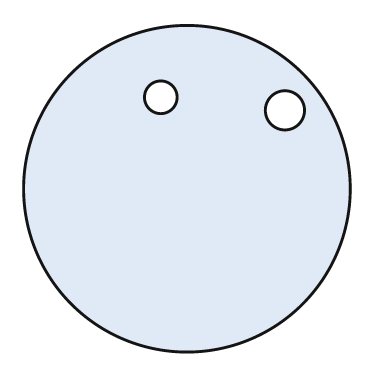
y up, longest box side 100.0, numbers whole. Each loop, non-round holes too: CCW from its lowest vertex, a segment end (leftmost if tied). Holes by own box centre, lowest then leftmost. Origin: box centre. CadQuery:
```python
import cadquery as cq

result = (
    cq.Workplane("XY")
    .moveTo(0.0, 0.0)
    .circle(50.0)
    .moveTo(30.0, 24.0)
    .circle(6.0)
    .moveTo(-8.0, 28.0)
    .circle(5.0)
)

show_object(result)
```